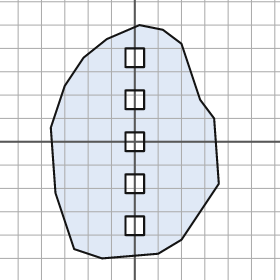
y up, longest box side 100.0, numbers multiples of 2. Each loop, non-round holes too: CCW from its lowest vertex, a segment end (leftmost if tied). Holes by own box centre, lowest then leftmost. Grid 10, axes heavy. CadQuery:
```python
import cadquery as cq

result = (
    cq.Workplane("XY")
    .moveTo(-14.0, -50.0)
    .lineTo(10.0, -48.0)
    .lineTo(20.0, -42.0)
    .lineTo(36.0, -18.0)
    .lineTo(34.0, 10.0)
    .lineTo(28.0, 18.0)
    .lineTo(20.0, 42.0)
    .lineTo(12.0, 48.0)
    .lineTo(2.0, 50.0)
    .lineTo(-12.0, 44.0)
    .lineTo(-22.0, 36.0)
    .lineTo(-30.0, 24.0)
    .lineTo(-36.0, 6.0)
    .lineTo(-34.0, -22.0)
    .lineTo(-26.0, -46.0)
    .close()
    .moveTo(-4.0, -40.0)
    .lineTo(4.0, -40.0)
    .lineTo(4.0, -32.0)
    .lineTo(-4.0, -32.0)
    .close()
    .moveTo(-4.0, -22.0)
    .lineTo(4.0, -22.0)
    .lineTo(4.0, -14.0)
    .lineTo(-4.0, -14.0)
    .close()
    .moveTo(-4.0, -4.0)
    .lineTo(4.0, -4.0)
    .lineTo(4.0, 4.0)
    .lineTo(-4.0, 4.0)
    .close()
    .moveTo(-4.0, 14.0)
    .lineTo(4.0, 14.0)
    .lineTo(4.0, 22.0)
    .lineTo(-4.0, 22.0)
    .close()
    .moveTo(-4.0, 32.0)
    .lineTo(4.0, 32.0)
    .lineTo(4.0, 40.0)
    .lineTo(-4.0, 40.0)
    .close()
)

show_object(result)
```